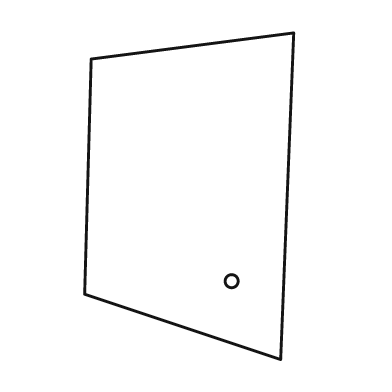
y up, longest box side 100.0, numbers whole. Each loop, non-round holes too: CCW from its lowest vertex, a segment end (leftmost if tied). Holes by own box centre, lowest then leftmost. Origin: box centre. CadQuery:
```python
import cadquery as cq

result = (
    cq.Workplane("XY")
    .moveTo(28.0, -50.0)
    .lineTo(32.0, 50.0)
    .lineTo(-30.0, 42.0)
    .lineTo(-32.0, -30.0)
    .close()
    .moveTo(13.0, -26.0)
    .circle(2.0)
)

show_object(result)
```